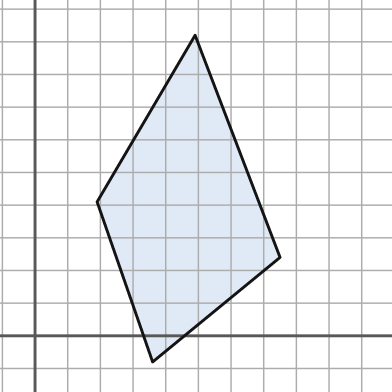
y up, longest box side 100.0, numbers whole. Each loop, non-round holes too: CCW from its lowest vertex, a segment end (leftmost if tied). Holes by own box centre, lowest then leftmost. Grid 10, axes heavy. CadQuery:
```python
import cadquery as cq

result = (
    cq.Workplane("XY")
    .moveTo(36.0, -8.0)
    .lineTo(75.0, 24.0)
    .lineTo(49.0, 92.0)
    .lineTo(19.0, 41.0)
    .close()
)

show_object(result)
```